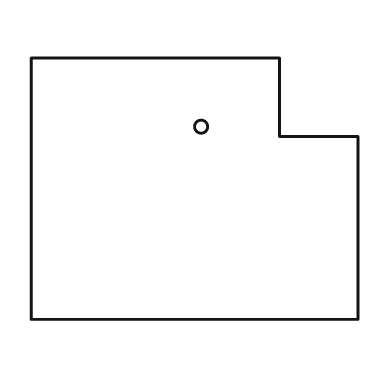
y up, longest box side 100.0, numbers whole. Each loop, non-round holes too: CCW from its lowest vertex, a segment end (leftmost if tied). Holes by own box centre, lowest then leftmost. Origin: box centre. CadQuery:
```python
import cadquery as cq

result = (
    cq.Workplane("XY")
    .moveTo(-50.0, -40.0)
    .lineTo(50.0, -40.0)
    .lineTo(50.0, 16.0)
    .lineTo(26.0, 16.0)
    .lineTo(26.0, 40.0)
    .lineTo(-50.0, 40.0)
    .close()
    .moveTo(2.0, 19.0)
    .circle(2.0)
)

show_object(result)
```